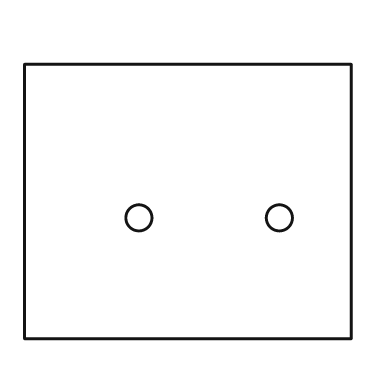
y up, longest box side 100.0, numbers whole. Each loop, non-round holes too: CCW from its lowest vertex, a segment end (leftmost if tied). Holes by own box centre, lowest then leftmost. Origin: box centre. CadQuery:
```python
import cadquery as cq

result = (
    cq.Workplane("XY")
    .moveTo(-50.0, -42.0)
    .lineTo(50.0, -42.0)
    .lineTo(50.0, 42.0)
    .lineTo(-50.0, 42.0)
    .close()
    .moveTo(-15.0, -5.0)
    .circle(4.0)
    .moveTo(28.0, -5.0)
    .circle(4.0)
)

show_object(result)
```